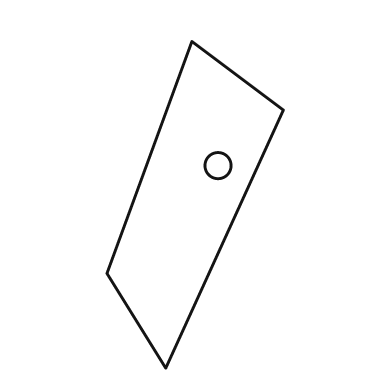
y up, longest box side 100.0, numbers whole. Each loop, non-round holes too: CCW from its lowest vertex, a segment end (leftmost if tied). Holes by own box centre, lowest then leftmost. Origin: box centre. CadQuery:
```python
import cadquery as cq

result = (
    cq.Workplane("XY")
    .moveTo(-9.0, -50.0)
    .lineTo(27.0, 29.0)
    .lineTo(-1.0, 50.0)
    .lineTo(-27.0, -21.0)
    .close()
    .moveTo(7.0, 12.0)
    .circle(4.0)
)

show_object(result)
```